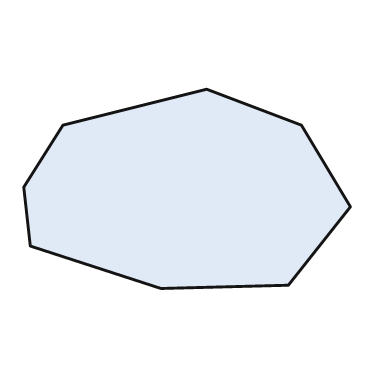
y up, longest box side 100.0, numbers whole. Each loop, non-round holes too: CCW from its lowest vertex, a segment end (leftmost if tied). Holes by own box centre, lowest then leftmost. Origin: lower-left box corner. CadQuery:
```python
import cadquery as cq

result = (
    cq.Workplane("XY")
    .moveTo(42.0, 0.0)
    .lineTo(81.0, 1.0)
    .lineTo(100.0, 25.0)
    .lineTo(85.0, 50.0)
    .lineTo(56.0, 61.0)
    .lineTo(12.0, 50.0)
    .lineTo(0.0, 31.0)
    .lineTo(2.0, 13.0)
    .close()
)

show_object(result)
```